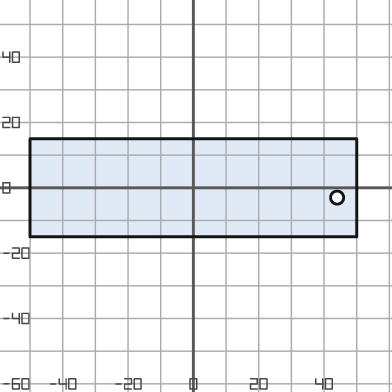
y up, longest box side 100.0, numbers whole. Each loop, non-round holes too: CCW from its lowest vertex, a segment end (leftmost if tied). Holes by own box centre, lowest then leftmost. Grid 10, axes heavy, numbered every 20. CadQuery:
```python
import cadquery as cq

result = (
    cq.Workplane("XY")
    .moveTo(-50.0, -15.0)
    .lineTo(50.0, -15.0)
    .lineTo(50.0, 15.0)
    .lineTo(-50.0, 15.0)
    .close()
    .moveTo(44.0, -3.0)
    .circle(2.0)
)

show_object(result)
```